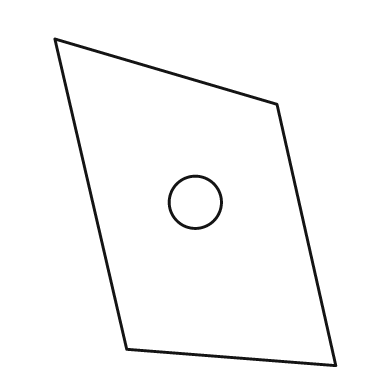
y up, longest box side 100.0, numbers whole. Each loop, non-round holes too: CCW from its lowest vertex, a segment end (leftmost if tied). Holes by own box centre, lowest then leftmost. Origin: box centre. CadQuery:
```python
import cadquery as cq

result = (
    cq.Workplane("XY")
    .moveTo(43.0, -50.0)
    .lineTo(25.0, 30.0)
    .lineTo(-43.0, 50.0)
    .lineTo(-21.0, -45.0)
    .close()
    .moveTo(0.0, 0.0)
    .circle(8.0)
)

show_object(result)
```